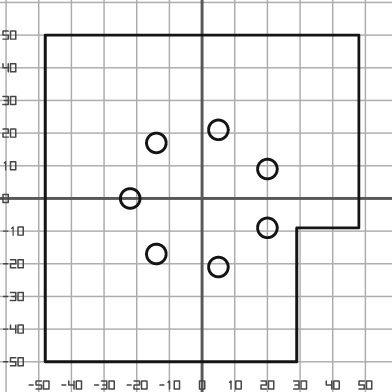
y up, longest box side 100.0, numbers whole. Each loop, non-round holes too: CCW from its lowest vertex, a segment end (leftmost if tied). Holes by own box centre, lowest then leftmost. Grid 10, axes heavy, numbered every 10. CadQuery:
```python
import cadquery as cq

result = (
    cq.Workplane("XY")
    .moveTo(-48.0, -50.0)
    .lineTo(29.0, -50.0)
    .lineTo(29.0, -9.0)
    .lineTo(48.0, -9.0)
    .lineTo(48.0, 50.0)
    .lineTo(-48.0, 50.0)
    .close()
    .moveTo(5.0, -21.0)
    .circle(3.0)
    .moveTo(-14.0, -17.0)
    .circle(3.0)
    .moveTo(20.0, -9.0)
    .circle(3.0)
    .moveTo(-22.0, 0.0)
    .circle(3.0)
    .moveTo(20.0, 9.0)
    .circle(3.0)
    .moveTo(-14.0, 17.0)
    .circle(3.0)
    .moveTo(5.0, 21.0)
    .circle(3.0)
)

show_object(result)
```